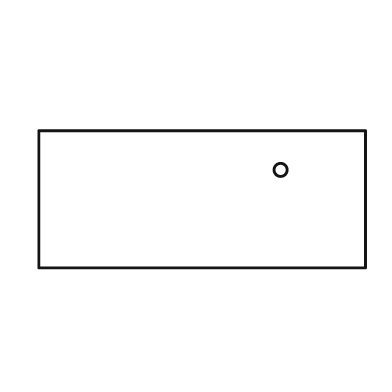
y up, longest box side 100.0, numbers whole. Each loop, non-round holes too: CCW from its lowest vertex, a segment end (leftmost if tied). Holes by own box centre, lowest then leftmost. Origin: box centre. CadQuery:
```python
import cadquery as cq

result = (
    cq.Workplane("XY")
    .moveTo(-50.0, -21.0)
    .lineTo(50.0, -21.0)
    .lineTo(50.0, 21.0)
    .lineTo(-50.0, 21.0)
    .close()
    .moveTo(24.0, 9.0)
    .circle(2.0)
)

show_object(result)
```